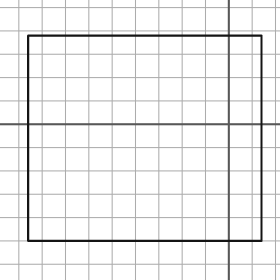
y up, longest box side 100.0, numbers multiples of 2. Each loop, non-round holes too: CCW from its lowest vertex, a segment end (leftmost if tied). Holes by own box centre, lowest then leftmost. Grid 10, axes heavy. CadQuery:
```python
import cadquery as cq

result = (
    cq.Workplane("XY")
    .moveTo(-86.0, -50.0)
    .lineTo(14.0, -50.0)
    .lineTo(14.0, 38.0)
    .lineTo(-86.0, 38.0)
    .close()
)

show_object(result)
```